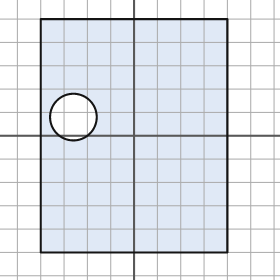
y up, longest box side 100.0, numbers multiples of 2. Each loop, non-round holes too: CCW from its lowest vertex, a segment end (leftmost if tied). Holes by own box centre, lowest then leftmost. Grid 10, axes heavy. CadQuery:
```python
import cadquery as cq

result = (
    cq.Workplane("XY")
    .moveTo(-40.0, -50.0)
    .lineTo(40.0, -50.0)
    .lineTo(40.0, 50.0)
    .lineTo(-40.0, 50.0)
    .close()
    .moveTo(-26.0, 8.0)
    .circle(10.0)
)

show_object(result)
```